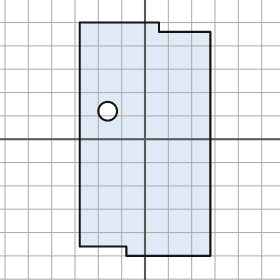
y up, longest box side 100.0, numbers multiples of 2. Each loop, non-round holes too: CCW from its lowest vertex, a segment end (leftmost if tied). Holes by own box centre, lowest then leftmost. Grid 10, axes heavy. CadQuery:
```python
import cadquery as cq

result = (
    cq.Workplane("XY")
    .moveTo(-8.0, -50.0)
    .lineTo(28.0, -50.0)
    .lineTo(28.0, 46.0)
    .lineTo(6.0, 46.0)
    .lineTo(6.0, 50.0)
    .lineTo(-28.0, 50.0)
    .lineTo(-28.0, -46.0)
    .lineTo(-8.0, -46.0)
    .close()
    .moveTo(-16.0, 12.0)
    .circle(4.0)
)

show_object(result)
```